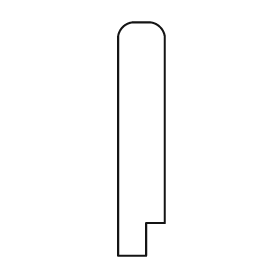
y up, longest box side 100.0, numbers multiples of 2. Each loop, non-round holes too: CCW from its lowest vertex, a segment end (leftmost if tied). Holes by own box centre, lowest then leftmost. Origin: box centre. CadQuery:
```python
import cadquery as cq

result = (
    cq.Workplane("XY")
    .moveTo(-10.0, -50.0)
    .lineTo(2.0, -50.0)
    .lineTo(2.0, -36.0)
    .lineTo(10.0, -36.0)
    .lineTo(10.0, 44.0)
    .threePointArc((8.0, 48.0), (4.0, 50.0))
    .lineTo(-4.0, 50.0)
    .threePointArc((-8.0, 48.0), (-10.0, 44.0))
    .close()
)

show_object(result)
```